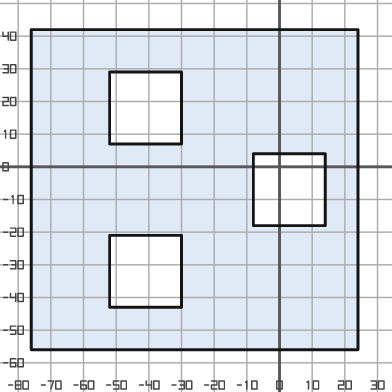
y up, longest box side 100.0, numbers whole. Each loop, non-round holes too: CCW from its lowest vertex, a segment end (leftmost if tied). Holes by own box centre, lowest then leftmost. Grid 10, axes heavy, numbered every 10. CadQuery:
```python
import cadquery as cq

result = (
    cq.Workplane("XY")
    .moveTo(-76.0, -56.0)
    .lineTo(24.0, -56.0)
    .lineTo(24.0, 42.0)
    .lineTo(-76.0, 42.0)
    .close()
    .moveTo(-52.0, -43.0)
    .lineTo(-30.0, -43.0)
    .lineTo(-30.0, -21.0)
    .lineTo(-52.0, -21.0)
    .close()
    .moveTo(-8.0, -18.0)
    .lineTo(14.0, -18.0)
    .lineTo(14.0, 4.0)
    .lineTo(-8.0, 4.0)
    .close()
    .moveTo(-52.0, 7.0)
    .lineTo(-30.0, 7.0)
    .lineTo(-30.0, 29.0)
    .lineTo(-52.0, 29.0)
    .close()
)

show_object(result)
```